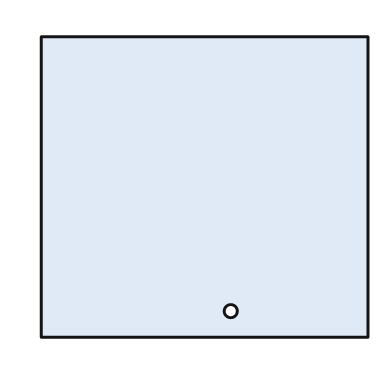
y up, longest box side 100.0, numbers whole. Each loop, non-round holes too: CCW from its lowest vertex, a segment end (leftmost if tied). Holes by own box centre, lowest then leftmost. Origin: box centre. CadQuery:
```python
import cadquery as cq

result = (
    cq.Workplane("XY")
    .moveTo(-50.0, -46.0)
    .lineTo(50.0, -46.0)
    .lineTo(50.0, 46.0)
    .lineTo(-50.0, 46.0)
    .close()
    .moveTo(8.0, -38.0)
    .circle(2.0)
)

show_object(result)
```